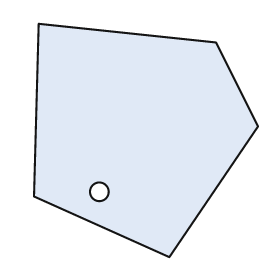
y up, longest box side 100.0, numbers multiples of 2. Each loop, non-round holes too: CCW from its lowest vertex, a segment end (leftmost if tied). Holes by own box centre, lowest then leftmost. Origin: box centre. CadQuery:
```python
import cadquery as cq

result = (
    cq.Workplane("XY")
    .moveTo(10.0, -50.0)
    .lineTo(48.0, 6.0)
    .lineTo(30.0, 42.0)
    .lineTo(-46.0, 50.0)
    .lineTo(-48.0, -24.0)
    .close()
    .moveTo(-20.0, -22.0)
    .circle(4.0)
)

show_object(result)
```